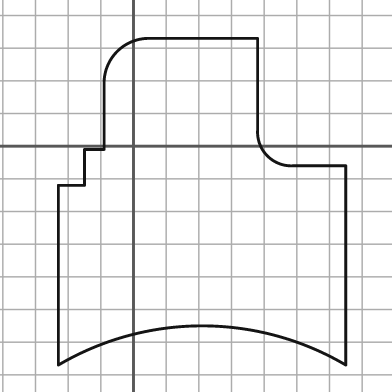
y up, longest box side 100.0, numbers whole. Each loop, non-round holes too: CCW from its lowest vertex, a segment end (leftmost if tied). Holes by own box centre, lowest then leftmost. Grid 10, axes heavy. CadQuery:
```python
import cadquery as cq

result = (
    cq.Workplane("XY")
    .moveTo(-23.0, -67.0)
    .threePointArc((21.0, -55.0), (65.0, -67.0))
    .lineTo(65.0, -6.0)
    .lineTo(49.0, -6.0)
    .threePointArc((41.0, -3.0), (38.0, 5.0))
    .lineTo(38.0, 33.0)
    .lineTo(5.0, 33.0)
    .threePointArc((-5.0, 29.0), (-9.0, 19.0))
    .lineTo(-9.0, -1.0)
    .lineTo(-15.0, -1.0)
    .lineTo(-15.0, -12.0)
    .lineTo(-23.0, -12.0)
    .close()
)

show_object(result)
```